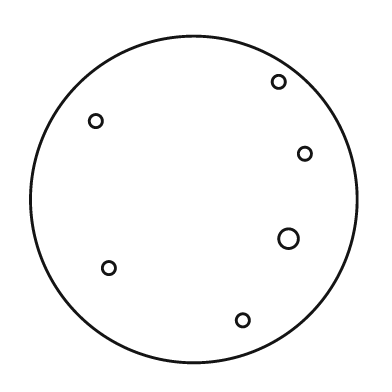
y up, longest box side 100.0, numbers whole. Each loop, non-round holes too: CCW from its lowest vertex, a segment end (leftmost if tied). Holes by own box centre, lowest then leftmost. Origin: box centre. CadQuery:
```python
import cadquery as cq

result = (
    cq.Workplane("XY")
    .moveTo(0.0, 0.0)
    .circle(50.0)
    .moveTo(15.0, -37.0)
    .circle(2.0)
    .moveTo(-26.0, -21.0)
    .circle(2.0)
    .moveTo(29.0, -12.0)
    .circle(3.0)
    .moveTo(34.0, 14.0)
    .circle(2.0)
    .moveTo(-30.0, 24.0)
    .circle(2.0)
    .moveTo(26.0, 36.0)
    .circle(2.0)
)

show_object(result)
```